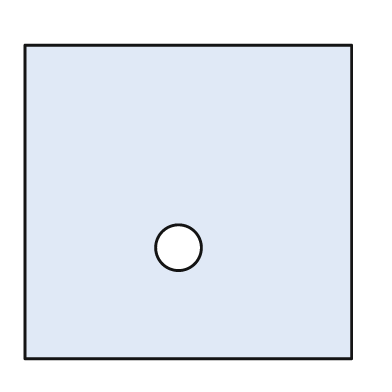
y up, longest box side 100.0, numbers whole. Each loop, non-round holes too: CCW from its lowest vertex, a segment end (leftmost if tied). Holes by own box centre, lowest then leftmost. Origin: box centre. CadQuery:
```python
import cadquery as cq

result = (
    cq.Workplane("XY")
    .moveTo(-50.0, -48.0)
    .lineTo(50.0, -48.0)
    .lineTo(50.0, 48.0)
    .lineTo(-50.0, 48.0)
    .close()
    .moveTo(-3.0, -14.0)
    .circle(7.0)
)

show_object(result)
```